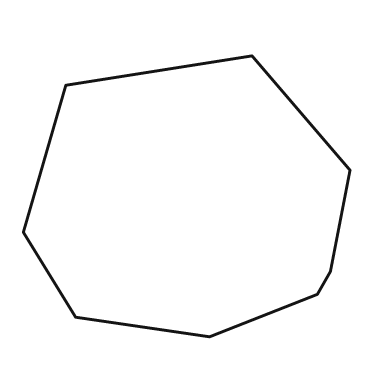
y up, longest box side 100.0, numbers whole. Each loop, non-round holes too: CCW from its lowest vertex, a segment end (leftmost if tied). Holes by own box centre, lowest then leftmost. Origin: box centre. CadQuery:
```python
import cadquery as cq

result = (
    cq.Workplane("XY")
    .moveTo(7.0, -43.0)
    .lineTo(40.0, -30.0)
    .lineTo(44.0, -23.0)
    .lineTo(50.0, 8.0)
    .lineTo(20.0, 43.0)
    .lineTo(-37.0, 34.0)
    .lineTo(-50.0, -11.0)
    .lineTo(-34.0, -37.0)
    .close()
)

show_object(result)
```